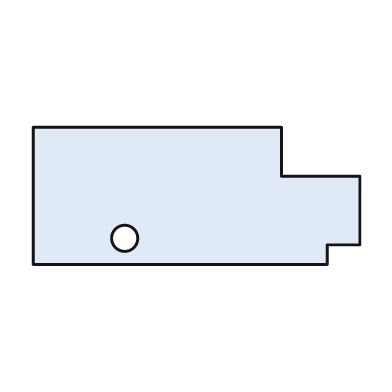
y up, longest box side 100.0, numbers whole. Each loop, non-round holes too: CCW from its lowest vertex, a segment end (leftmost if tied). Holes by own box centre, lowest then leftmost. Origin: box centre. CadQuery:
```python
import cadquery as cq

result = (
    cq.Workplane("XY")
    .moveTo(-50.0, -21.0)
    .lineTo(40.0, -21.0)
    .lineTo(40.0, -15.0)
    .lineTo(50.0, -15.0)
    .lineTo(50.0, 6.0)
    .lineTo(26.0, 6.0)
    .lineTo(26.0, 21.0)
    .lineTo(-50.0, 21.0)
    .close()
    .moveTo(-22.0, -13.0)
    .circle(4.0)
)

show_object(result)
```